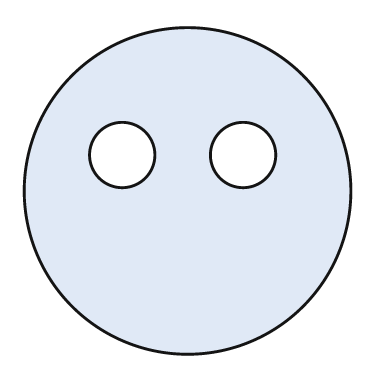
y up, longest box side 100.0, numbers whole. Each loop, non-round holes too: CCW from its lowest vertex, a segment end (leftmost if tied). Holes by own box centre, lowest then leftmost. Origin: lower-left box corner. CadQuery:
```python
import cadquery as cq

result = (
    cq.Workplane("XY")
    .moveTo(50.0, 50.0)
    .circle(50.0)
    .moveTo(30.0, 61.0)
    .circle(10.0)
    .moveTo(67.0, 61.0)
    .circle(10.0)
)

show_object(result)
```